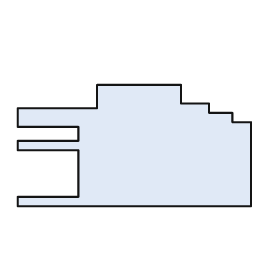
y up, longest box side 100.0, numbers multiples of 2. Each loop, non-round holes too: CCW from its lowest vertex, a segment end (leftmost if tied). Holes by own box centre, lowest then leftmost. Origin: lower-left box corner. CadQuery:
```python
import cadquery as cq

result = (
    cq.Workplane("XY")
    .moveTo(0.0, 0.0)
    .lineTo(100.0, 0.0)
    .lineTo(100.0, 36.0)
    .lineTo(92.0, 36.0)
    .lineTo(92.0, 40.0)
    .lineTo(82.0, 40.0)
    .lineTo(82.0, 44.0)
    .lineTo(70.0, 44.0)
    .lineTo(70.0, 52.0)
    .lineTo(34.0, 52.0)
    .lineTo(34.0, 42.0)
    .lineTo(0.0, 42.0)
    .lineTo(0.0, 34.0)
    .lineTo(26.0, 34.0)
    .lineTo(26.0, 28.0)
    .lineTo(0.0, 28.0)
    .lineTo(0.0, 24.0)
    .lineTo(26.0, 24.0)
    .lineTo(26.0, 4.0)
    .lineTo(0.0, 4.0)
    .close()
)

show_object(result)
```